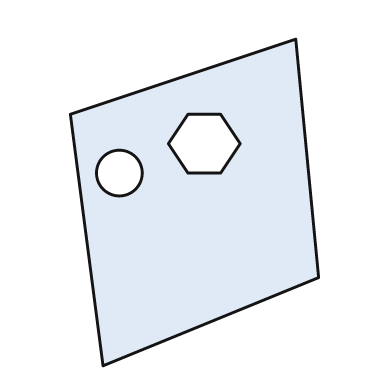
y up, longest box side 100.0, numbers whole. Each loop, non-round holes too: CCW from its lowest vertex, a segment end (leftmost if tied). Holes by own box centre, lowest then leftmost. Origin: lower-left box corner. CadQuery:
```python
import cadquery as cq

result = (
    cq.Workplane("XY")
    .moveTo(10.0, 0.0)
    .lineTo(76.0, 27.0)
    .lineTo(69.0, 100.0)
    .lineTo(0.0, 77.0)
    .close()
    .moveTo(15.0, 59.0)
    .circle(7.0)
    .moveTo(36.0, 59.0)
    .lineTo(46.0, 59.0)
    .lineTo(52.0, 68.0)
    .lineTo(46.0, 77.0)
    .lineTo(36.0, 77.0)
    .lineTo(30.0, 68.0)
    .close()
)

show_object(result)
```